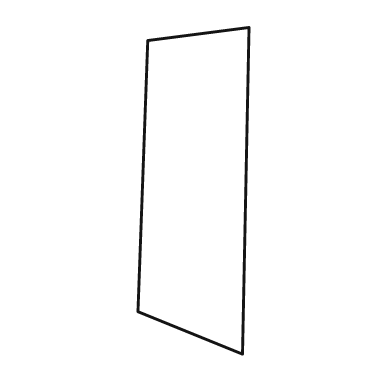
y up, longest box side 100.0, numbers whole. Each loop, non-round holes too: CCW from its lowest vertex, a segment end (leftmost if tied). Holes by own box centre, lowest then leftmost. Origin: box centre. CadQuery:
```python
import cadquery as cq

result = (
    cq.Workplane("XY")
    .moveTo(15.0, -50.0)
    .lineTo(17.0, 50.0)
    .lineTo(-14.0, 46.0)
    .lineTo(-17.0, -37.0)
    .close()
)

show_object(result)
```